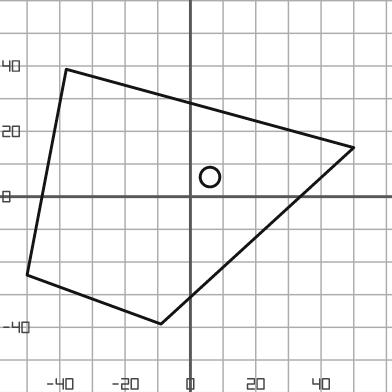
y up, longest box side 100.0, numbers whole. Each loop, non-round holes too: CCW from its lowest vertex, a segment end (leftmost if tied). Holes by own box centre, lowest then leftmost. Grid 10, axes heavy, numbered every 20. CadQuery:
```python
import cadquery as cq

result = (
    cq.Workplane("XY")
    .moveTo(-9.0, -39.0)
    .lineTo(50.0, 15.0)
    .lineTo(-38.0, 39.0)
    .lineTo(-50.0, -24.0)
    .close()
    .moveTo(6.0, 6.0)
    .circle(3.0)
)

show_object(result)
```